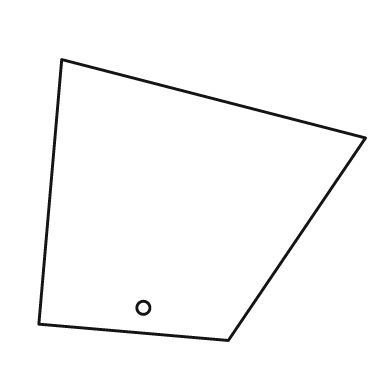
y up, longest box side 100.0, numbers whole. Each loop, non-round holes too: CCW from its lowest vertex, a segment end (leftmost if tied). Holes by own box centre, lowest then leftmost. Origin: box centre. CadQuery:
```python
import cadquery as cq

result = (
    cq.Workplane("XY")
    .moveTo(8.0, -43.0)
    .lineTo(50.0, 19.0)
    .lineTo(-43.0, 43.0)
    .lineTo(-50.0, -38.0)
    .close()
    .moveTo(-18.0, -33.0)
    .circle(2.0)
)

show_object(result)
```